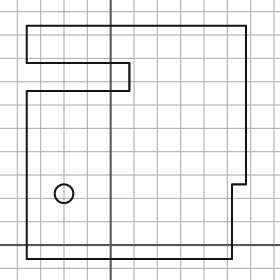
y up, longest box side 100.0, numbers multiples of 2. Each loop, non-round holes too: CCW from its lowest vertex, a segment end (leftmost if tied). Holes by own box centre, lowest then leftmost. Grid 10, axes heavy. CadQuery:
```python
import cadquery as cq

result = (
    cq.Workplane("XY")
    .moveTo(-36.0, -6.0)
    .lineTo(52.0, -6.0)
    .lineTo(52.0, 26.0)
    .lineTo(58.0, 26.0)
    .lineTo(58.0, 94.0)
    .lineTo(-36.0, 94.0)
    .lineTo(-36.0, 78.0)
    .lineTo(8.0, 78.0)
    .lineTo(8.0, 66.0)
    .lineTo(-36.0, 66.0)
    .close()
    .moveTo(-20.0, 22.0)
    .circle(4.0)
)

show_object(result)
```